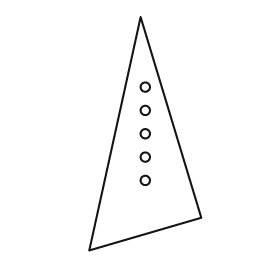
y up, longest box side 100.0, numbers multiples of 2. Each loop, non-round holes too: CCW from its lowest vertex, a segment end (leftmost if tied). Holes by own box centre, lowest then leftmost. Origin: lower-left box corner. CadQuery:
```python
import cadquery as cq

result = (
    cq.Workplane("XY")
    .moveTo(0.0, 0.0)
    .lineTo(48.0, 14.0)
    .lineTo(22.0, 100.0)
    .close()
    .moveTo(24.0, 30.0)
    .circle(2.0)
    .moveTo(24.0, 40.0)
    .circle(2.0)
    .moveTo(24.0, 50.0)
    .circle(2.0)
    .moveTo(24.0, 60.0)
    .circle(2.0)
    .moveTo(24.0, 70.0)
    .circle(2.0)
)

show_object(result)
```